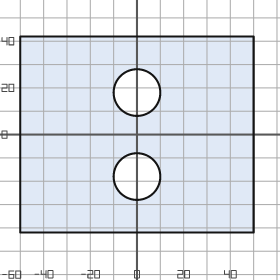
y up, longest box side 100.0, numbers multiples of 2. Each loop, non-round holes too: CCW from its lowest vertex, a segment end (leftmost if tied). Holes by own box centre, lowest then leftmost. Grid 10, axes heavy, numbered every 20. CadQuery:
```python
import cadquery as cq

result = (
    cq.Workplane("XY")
    .moveTo(-50.0, -42.0)
    .lineTo(50.0, -42.0)
    .lineTo(50.0, 42.0)
    .lineTo(-50.0, 42.0)
    .close()
    .moveTo(0.0, -18.0)
    .circle(10.0)
    .moveTo(0.0, 18.0)
    .circle(10.0)
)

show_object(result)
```